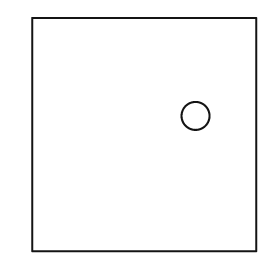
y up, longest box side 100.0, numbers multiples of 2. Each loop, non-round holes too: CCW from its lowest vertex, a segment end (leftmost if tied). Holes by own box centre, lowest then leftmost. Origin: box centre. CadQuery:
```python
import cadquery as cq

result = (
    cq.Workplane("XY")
    .moveTo(-48.0, -50.0)
    .lineTo(48.0, -50.0)
    .lineTo(48.0, 50.0)
    .lineTo(-48.0, 50.0)
    .close()
    .moveTo(22.0, 8.0)
    .circle(6.0)
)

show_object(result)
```